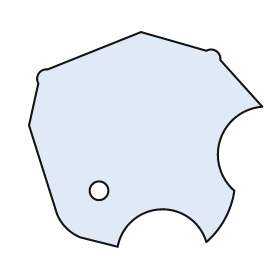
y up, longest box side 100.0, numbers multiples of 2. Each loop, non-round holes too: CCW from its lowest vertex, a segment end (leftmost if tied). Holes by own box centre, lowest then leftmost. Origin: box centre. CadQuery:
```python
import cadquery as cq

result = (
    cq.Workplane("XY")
    .moveTo(-12.0, -46.0)
    .threePointArc((6.0, -30.0), (26.0, -44.0))
    .threePointArc((34.0, -34.0), (38.0, -22.0))
    .threePointArc((32.0, 0.0), (50.0, 14.0))
    .lineTo(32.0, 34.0)
    .threePointArc((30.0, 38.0), (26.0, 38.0))
    .lineTo(-2.0, 46.0)
    .lineTo(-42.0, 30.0)
    .threePointArc((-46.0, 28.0), (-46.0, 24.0))
    .lineTo(-50.0, 6.0)
    .lineTo(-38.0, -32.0)
    .threePointArc((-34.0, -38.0), (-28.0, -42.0))
    .close()
    .moveTo(-20.0, -22.0)
    .circle(4.0)
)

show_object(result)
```